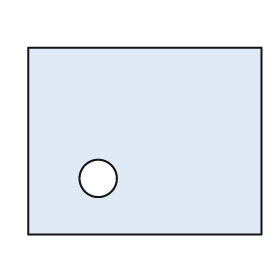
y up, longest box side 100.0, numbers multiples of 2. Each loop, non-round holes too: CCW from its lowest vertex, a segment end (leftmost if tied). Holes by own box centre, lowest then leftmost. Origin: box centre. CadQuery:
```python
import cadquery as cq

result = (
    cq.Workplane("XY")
    .moveTo(-50.0, -40.0)
    .lineTo(50.0, -40.0)
    .lineTo(50.0, 40.0)
    .lineTo(-50.0, 40.0)
    .close()
    .moveTo(-20.0, -16.0)
    .circle(8.0)
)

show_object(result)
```